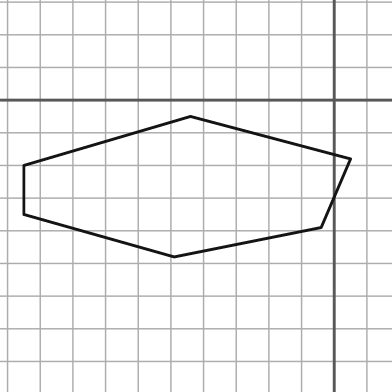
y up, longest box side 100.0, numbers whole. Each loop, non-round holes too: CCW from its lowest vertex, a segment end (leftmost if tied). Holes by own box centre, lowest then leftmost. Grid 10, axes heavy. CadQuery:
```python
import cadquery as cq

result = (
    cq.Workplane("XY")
    .moveTo(-49.0, -48.0)
    .lineTo(-4.0, -39.0)
    .lineTo(5.0, -18.0)
    .lineTo(-44.0, -5.0)
    .lineTo(-95.0, -20.0)
    .lineTo(-95.0, -35.0)
    .close()
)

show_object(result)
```